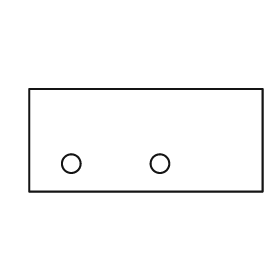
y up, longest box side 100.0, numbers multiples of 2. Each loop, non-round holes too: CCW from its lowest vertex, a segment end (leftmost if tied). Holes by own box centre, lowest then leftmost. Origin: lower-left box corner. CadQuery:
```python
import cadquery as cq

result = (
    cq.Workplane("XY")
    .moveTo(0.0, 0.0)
    .lineTo(100.0, 0.0)
    .lineTo(100.0, 44.0)
    .lineTo(0.0, 44.0)
    .close()
    .moveTo(18.0, 12.0)
    .circle(4.0)
    .moveTo(56.0, 12.0)
    .circle(4.0)
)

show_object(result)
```